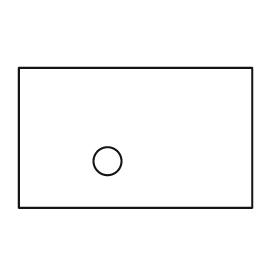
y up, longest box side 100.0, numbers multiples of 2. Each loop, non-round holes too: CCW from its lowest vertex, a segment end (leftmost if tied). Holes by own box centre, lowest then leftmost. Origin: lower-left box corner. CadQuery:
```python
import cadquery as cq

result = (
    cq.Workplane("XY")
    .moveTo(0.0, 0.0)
    .lineTo(100.0, 0.0)
    .lineTo(100.0, 60.0)
    .lineTo(0.0, 60.0)
    .close()
    .moveTo(38.0, 20.0)
    .circle(6.0)
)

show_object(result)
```